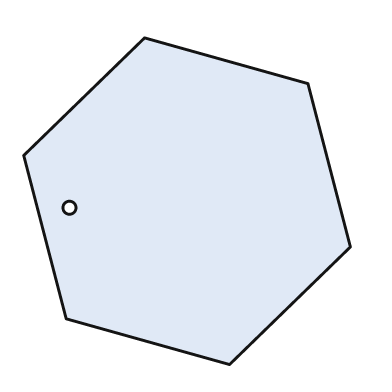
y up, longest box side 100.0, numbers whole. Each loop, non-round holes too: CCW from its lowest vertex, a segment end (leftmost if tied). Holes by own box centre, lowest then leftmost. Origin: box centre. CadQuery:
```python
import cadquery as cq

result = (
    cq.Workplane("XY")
    .moveTo(13.0, -50.0)
    .lineTo(50.0, -14.0)
    .lineTo(37.0, 36.0)
    .lineTo(-13.0, 50.0)
    .lineTo(-50.0, 14.0)
    .lineTo(-37.0, -36.0)
    .close()
    .moveTo(-36.0, -2.0)
    .circle(2.0)
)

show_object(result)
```